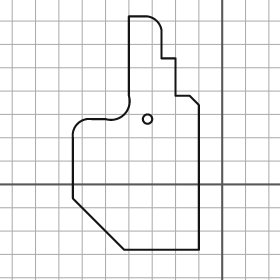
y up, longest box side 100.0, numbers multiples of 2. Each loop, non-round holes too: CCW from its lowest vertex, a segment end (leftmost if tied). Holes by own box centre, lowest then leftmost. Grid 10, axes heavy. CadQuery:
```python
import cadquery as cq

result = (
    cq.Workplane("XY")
    .moveTo(-42.0, -28.0)
    .lineTo(-10.0, -28.0)
    .lineTo(-10.0, 34.0)
    .lineTo(-14.0, 38.0)
    .lineTo(-20.0, 38.0)
    .lineTo(-20.0, 54.0)
    .lineTo(-26.0, 54.0)
    .lineTo(-26.0, 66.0)
    .threePointArc((-28.0, 70.0), (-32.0, 72.0))
    .lineTo(-40.0, 72.0)
    .lineTo(-40.0, 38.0)
    .threePointArc((-42.0, 30.0), (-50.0, 28.0))
    .lineTo(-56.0, 28.0)
    .threePointArc((-62.0, 26.0), (-64.0, 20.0))
    .lineTo(-64.0, -6.0)
    .close()
    .moveTo(-32.0, 28.0)
    .circle(2.0)
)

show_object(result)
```